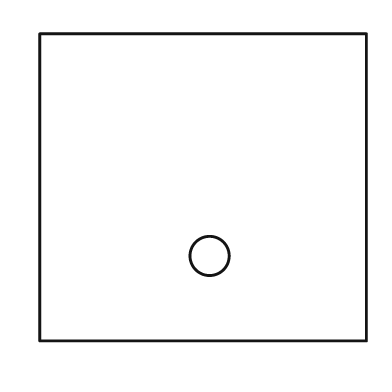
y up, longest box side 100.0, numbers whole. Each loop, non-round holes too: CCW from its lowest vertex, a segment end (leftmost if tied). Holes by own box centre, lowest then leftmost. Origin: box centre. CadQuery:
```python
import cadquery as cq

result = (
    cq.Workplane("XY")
    .moveTo(-50.0, -47.0)
    .lineTo(50.0, -47.0)
    .lineTo(50.0, 47.0)
    .lineTo(-50.0, 47.0)
    .close()
    .moveTo(2.0, -21.0)
    .circle(6.0)
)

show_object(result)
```